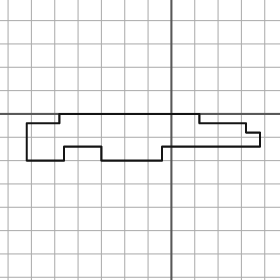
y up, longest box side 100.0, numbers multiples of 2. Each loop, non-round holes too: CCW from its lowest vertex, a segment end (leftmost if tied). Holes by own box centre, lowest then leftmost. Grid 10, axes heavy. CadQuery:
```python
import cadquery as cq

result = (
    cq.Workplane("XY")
    .moveTo(-62.0, -20.0)
    .lineTo(-46.0, -20.0)
    .lineTo(-46.0, -14.0)
    .lineTo(-30.0, -14.0)
    .lineTo(-30.0, -20.0)
    .lineTo(-4.0, -20.0)
    .lineTo(-4.0, -14.0)
    .lineTo(38.0, -14.0)
    .lineTo(38.0, -8.0)
    .lineTo(32.0, -8.0)
    .lineTo(32.0, -4.0)
    .lineTo(12.0, -4.0)
    .lineTo(12.0, 0.0)
    .lineTo(-48.0, 0.0)
    .lineTo(-48.0, -4.0)
    .lineTo(-62.0, -4.0)
    .close()
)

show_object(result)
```